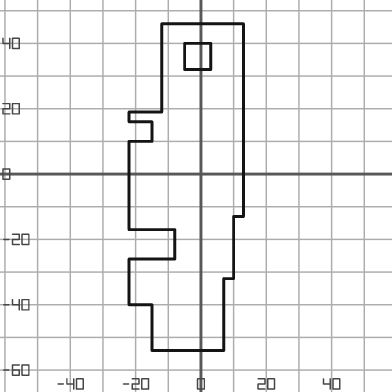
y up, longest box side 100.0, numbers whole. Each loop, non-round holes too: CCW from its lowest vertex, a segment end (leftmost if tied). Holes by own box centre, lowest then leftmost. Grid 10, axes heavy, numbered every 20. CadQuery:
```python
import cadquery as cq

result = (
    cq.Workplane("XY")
    .moveTo(-15.0, -54.0)
    .lineTo(7.0, -54.0)
    .lineTo(7.0, -32.0)
    .lineTo(10.0, -32.0)
    .lineTo(10.0, -13.0)
    .lineTo(13.0, -13.0)
    .lineTo(13.0, 46.0)
    .lineTo(-12.0, 46.0)
    .lineTo(-12.0, 19.0)
    .lineTo(-22.0, 19.0)
    .lineTo(-22.0, 16.0)
    .lineTo(-15.0, 16.0)
    .lineTo(-15.0, 10.0)
    .lineTo(-22.0, 10.0)
    .lineTo(-22.0, -17.0)
    .lineTo(-8.0, -17.0)
    .lineTo(-8.0, -26.0)
    .lineTo(-22.0, -26.0)
    .lineTo(-22.0, -40.0)
    .lineTo(-15.0, -40.0)
    .close()
    .moveTo(-5.0, 32.0)
    .lineTo(3.0, 32.0)
    .lineTo(3.0, 40.0)
    .lineTo(-5.0, 40.0)
    .close()
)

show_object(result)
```